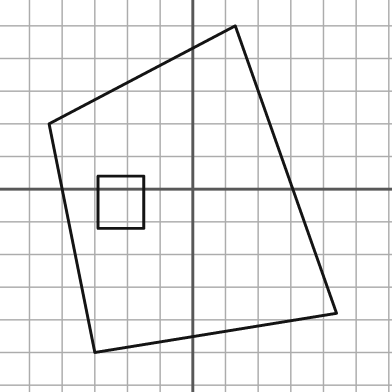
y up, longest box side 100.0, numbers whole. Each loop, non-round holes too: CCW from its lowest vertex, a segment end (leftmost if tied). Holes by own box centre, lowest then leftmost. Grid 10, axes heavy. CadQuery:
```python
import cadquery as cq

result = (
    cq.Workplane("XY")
    .moveTo(-30.0, -50.0)
    .lineTo(44.0, -38.0)
    .lineTo(13.0, 50.0)
    .lineTo(-44.0, 20.0)
    .close()
    .moveTo(-29.0, -12.0)
    .lineTo(-15.0, -12.0)
    .lineTo(-15.0, 4.0)
    .lineTo(-29.0, 4.0)
    .close()
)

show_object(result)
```